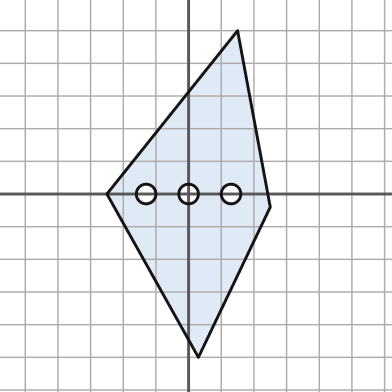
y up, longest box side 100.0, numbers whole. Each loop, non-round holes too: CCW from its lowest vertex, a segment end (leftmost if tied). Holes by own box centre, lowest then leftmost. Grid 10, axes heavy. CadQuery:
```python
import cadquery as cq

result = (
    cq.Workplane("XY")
    .moveTo(3.0, -50.0)
    .lineTo(25.0, -4.0)
    .lineTo(15.0, 50.0)
    .lineTo(-25.0, 0.0)
    .close()
    .moveTo(-13.0, 0.0)
    .circle(3.0)
    .moveTo(0.0, 0.0)
    .circle(3.0)
    .moveTo(13.0, 0.0)
    .circle(3.0)
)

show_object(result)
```